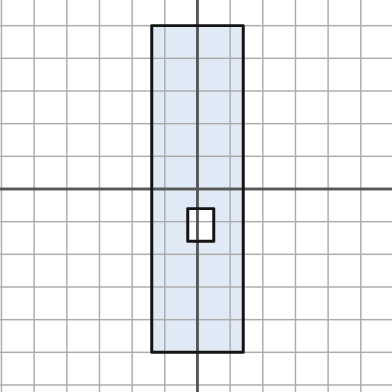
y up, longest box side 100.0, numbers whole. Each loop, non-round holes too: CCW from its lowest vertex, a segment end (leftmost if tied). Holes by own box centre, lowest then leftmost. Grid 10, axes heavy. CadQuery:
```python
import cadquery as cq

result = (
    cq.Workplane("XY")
    .moveTo(-14.0, -50.0)
    .lineTo(14.0, -50.0)
    .lineTo(14.0, 50.0)
    .lineTo(-14.0, 50.0)
    .close()
    .moveTo(-3.0, -16.0)
    .lineTo(5.0, -16.0)
    .lineTo(5.0, -6.0)
    .lineTo(-3.0, -6.0)
    .close()
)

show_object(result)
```